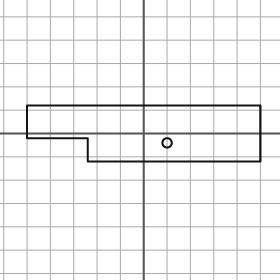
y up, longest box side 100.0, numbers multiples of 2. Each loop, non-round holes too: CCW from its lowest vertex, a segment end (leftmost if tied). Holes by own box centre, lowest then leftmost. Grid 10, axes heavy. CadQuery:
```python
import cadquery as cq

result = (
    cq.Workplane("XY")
    .moveTo(-24.0, -12.0)
    .lineTo(50.0, -12.0)
    .lineTo(50.0, 12.0)
    .lineTo(-50.0, 12.0)
    .lineTo(-50.0, -2.0)
    .lineTo(-24.0, -2.0)
    .close()
    .moveTo(10.0, -4.0)
    .circle(2.0)
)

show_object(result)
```